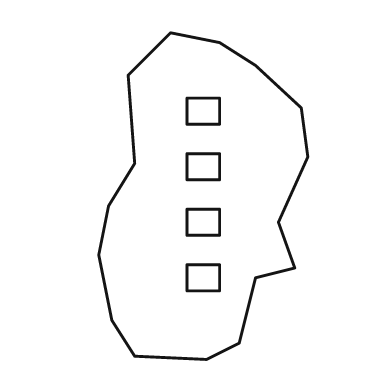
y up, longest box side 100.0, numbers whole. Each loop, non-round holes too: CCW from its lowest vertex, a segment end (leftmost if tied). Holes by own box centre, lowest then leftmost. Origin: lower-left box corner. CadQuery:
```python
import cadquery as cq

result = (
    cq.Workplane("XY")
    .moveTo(33.0, 0.0)
    .lineTo(43.0, 5.0)
    .lineTo(48.0, 25.0)
    .lineTo(60.0, 28.0)
    .lineTo(55.0, 42.0)
    .lineTo(64.0, 62.0)
    .lineTo(62.0, 77.0)
    .lineTo(48.0, 90.0)
    .lineTo(37.0, 97.0)
    .lineTo(22.0, 100.0)
    .lineTo(9.0, 87.0)
    .lineTo(11.0, 60.0)
    .lineTo(3.0, 47.0)
    .lineTo(0.0, 32.0)
    .lineTo(4.0, 12.0)
    .lineTo(11.0, 1.0)
    .close()
    .moveTo(27.0, 21.0)
    .lineTo(37.0, 21.0)
    .lineTo(37.0, 29.0)
    .lineTo(27.0, 29.0)
    .close()
    .moveTo(27.0, 38.0)
    .lineTo(37.0, 38.0)
    .lineTo(37.0, 46.0)
    .lineTo(27.0, 46.0)
    .close()
    .moveTo(27.0, 55.0)
    .lineTo(37.0, 55.0)
    .lineTo(37.0, 63.0)
    .lineTo(27.0, 63.0)
    .close()
    .moveTo(27.0, 72.0)
    .lineTo(37.0, 72.0)
    .lineTo(37.0, 80.0)
    .lineTo(27.0, 80.0)
    .close()
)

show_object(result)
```